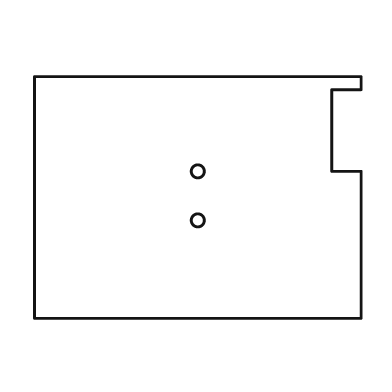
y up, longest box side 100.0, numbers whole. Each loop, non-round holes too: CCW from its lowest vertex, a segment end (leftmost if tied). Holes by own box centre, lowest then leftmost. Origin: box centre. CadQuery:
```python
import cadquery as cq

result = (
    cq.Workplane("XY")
    .moveTo(-50.0, -37.0)
    .lineTo(50.0, -37.0)
    .lineTo(50.0, 8.0)
    .lineTo(41.0, 8.0)
    .lineTo(41.0, 33.0)
    .lineTo(50.0, 33.0)
    .lineTo(50.0, 37.0)
    .lineTo(-50.0, 37.0)
    .close()
    .moveTo(0.0, -7.0)
    .circle(2.0)
    .moveTo(0.0, 8.0)
    .circle(2.0)
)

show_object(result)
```